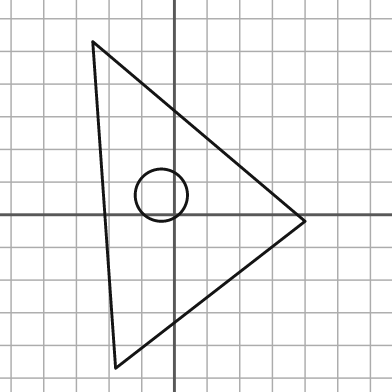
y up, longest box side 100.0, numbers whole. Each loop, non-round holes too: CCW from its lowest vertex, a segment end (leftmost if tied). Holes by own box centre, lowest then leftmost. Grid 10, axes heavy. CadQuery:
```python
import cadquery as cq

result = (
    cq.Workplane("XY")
    .moveTo(-18.0, -47.0)
    .lineTo(40.0, -2.0)
    .lineTo(-25.0, 53.0)
    .close()
    .moveTo(-4.0, 6.0)
    .circle(8.0)
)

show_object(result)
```